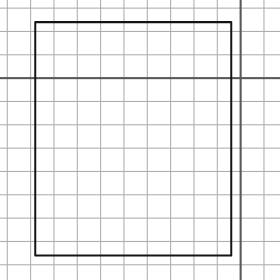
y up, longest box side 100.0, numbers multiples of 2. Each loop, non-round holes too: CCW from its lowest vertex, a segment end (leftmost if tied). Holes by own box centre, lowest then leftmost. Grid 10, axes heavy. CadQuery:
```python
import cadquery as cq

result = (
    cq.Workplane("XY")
    .moveTo(-88.0, -76.0)
    .lineTo(-4.0, -76.0)
    .lineTo(-4.0, 24.0)
    .lineTo(-88.0, 24.0)
    .close()
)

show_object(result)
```